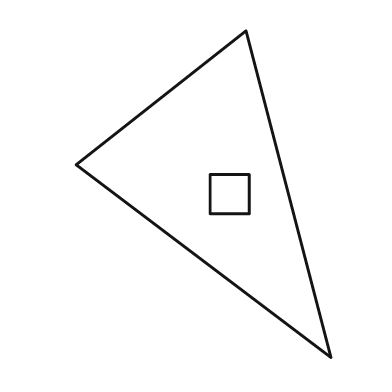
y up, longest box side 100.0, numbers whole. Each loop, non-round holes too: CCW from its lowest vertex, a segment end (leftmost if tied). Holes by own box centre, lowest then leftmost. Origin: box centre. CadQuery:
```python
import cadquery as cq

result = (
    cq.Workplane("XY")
    .moveTo(39.0, -50.0)
    .lineTo(13.0, 50.0)
    .lineTo(-39.0, 9.0)
    .close()
    .moveTo(2.0, -6.0)
    .lineTo(14.0, -6.0)
    .lineTo(14.0, 6.0)
    .lineTo(2.0, 6.0)
    .close()
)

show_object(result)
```